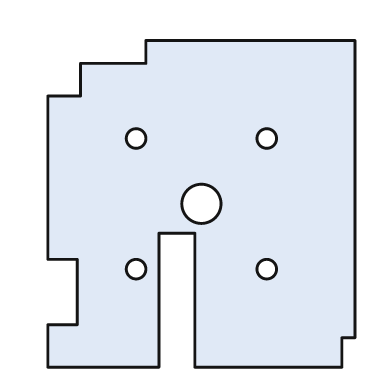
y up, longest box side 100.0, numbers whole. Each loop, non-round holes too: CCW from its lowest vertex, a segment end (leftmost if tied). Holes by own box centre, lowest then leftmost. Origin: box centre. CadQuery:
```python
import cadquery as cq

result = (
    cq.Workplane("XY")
    .moveTo(-47.0, -50.0)
    .lineTo(-13.0, -50.0)
    .lineTo(-13.0, -9.0)
    .lineTo(-2.0, -9.0)
    .lineTo(-2.0, -50.0)
    .lineTo(43.0, -50.0)
    .lineTo(43.0, -41.0)
    .lineTo(47.0, -41.0)
    .lineTo(47.0, 50.0)
    .lineTo(-17.0, 50.0)
    .lineTo(-17.0, 43.0)
    .lineTo(-37.0, 43.0)
    .lineTo(-37.0, 33.0)
    .lineTo(-47.0, 33.0)
    .lineTo(-47.0, -17.0)
    .lineTo(-38.0, -17.0)
    .lineTo(-38.0, -37.0)
    .lineTo(-47.0, -37.0)
    .close()
    .moveTo(-20.0, -20.0)
    .circle(3.0)
    .moveTo(20.0, -20.0)
    .circle(3.0)
    .moveTo(0.0, 0.0)
    .circle(6.0)
    .moveTo(-20.0, 20.0)
    .circle(3.0)
    .moveTo(20.0, 20.0)
    .circle(3.0)
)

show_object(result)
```